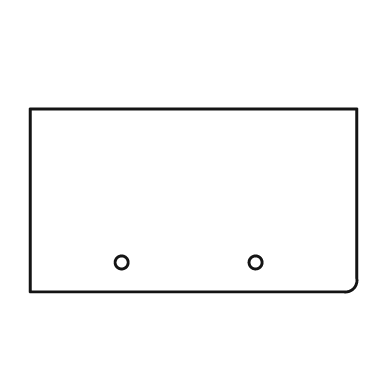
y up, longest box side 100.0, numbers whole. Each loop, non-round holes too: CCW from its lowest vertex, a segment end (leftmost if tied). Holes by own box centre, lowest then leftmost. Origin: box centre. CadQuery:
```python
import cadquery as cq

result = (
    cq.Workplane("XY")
    .moveTo(-50.0, -28.0)
    .lineTo(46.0, -28.0)
    .threePointArc((49.0, -27.0), (50.0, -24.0))
    .lineTo(50.0, 28.0)
    .lineTo(-50.0, 28.0)
    .close()
    .moveTo(-22.0, -19.0)
    .circle(2.0)
    .moveTo(19.0, -19.0)
    .circle(2.0)
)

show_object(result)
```